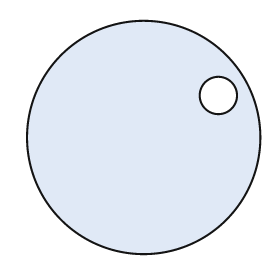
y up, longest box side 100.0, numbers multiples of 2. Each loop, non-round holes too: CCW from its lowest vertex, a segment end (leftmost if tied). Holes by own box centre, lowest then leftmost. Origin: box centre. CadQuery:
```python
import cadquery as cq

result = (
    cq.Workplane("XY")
    .moveTo(0.0, 0.0)
    .circle(50.0)
    .moveTo(32.0, 18.0)
    .circle(8.0)
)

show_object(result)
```